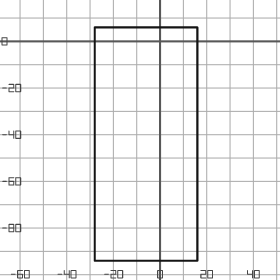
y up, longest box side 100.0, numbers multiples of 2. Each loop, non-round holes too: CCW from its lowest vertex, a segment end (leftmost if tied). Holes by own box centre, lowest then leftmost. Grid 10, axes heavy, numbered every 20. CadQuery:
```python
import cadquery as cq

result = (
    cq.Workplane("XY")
    .moveTo(-28.0, -94.0)
    .lineTo(16.0, -94.0)
    .lineTo(16.0, 6.0)
    .lineTo(-28.0, 6.0)
    .close()
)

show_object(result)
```